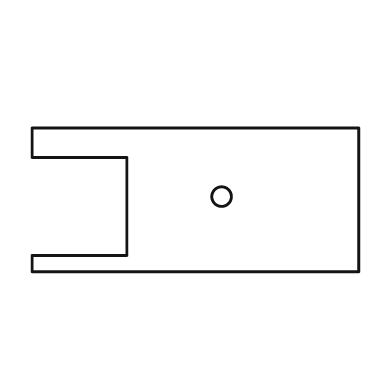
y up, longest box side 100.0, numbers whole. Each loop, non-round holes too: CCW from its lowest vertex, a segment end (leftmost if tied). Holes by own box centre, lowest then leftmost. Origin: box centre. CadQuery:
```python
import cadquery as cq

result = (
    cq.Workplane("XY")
    .moveTo(-50.0, -22.0)
    .lineTo(50.0, -22.0)
    .lineTo(50.0, 22.0)
    .lineTo(-50.0, 22.0)
    .lineTo(-50.0, 13.0)
    .lineTo(-21.0, 13.0)
    .lineTo(-21.0, -17.0)
    .lineTo(-50.0, -17.0)
    .close()
    .moveTo(8.0, 1.0)
    .circle(3.0)
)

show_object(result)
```